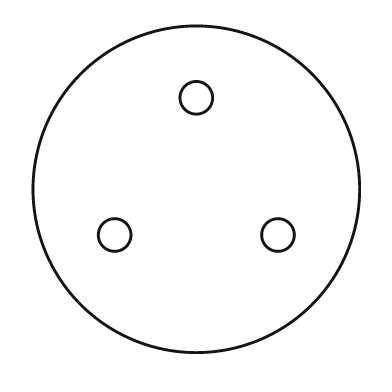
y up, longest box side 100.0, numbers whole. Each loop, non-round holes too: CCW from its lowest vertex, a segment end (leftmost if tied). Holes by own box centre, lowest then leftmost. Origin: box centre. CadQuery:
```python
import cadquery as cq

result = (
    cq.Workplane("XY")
    .moveTo(0.0, 0.0)
    .circle(50.0)
    .moveTo(-25.0, -14.0)
    .circle(5.0)
    .moveTo(25.0, -14.0)
    .circle(5.0)
    .moveTo(0.0, 28.0)
    .circle(5.0)
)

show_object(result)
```